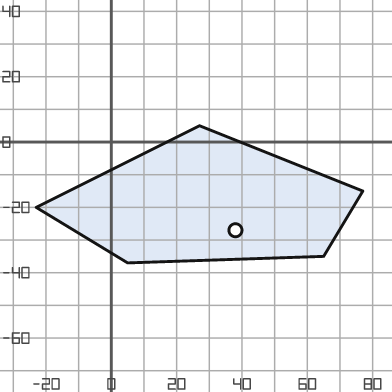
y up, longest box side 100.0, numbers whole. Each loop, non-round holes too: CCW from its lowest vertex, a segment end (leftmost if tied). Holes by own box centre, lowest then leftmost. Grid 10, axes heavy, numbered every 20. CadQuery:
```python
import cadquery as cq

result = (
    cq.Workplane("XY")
    .moveTo(5.0, -37.0)
    .lineTo(65.0, -35.0)
    .lineTo(77.0, -15.0)
    .lineTo(27.0, 5.0)
    .lineTo(-23.0, -20.0)
    .close()
    .moveTo(38.0, -27.0)
    .circle(2.0)
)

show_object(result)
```